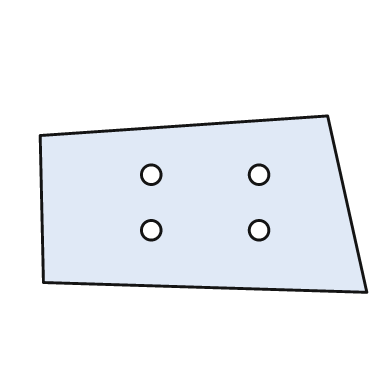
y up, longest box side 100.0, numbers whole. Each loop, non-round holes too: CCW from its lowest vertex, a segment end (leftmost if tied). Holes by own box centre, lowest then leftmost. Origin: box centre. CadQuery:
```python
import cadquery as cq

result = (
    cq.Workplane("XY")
    .moveTo(50.0, -27.0)
    .lineTo(38.0, 27.0)
    .lineTo(-50.0, 21.0)
    .lineTo(-49.0, -24.0)
    .close()
    .moveTo(-16.0, -8.0)
    .circle(3.0)
    .moveTo(17.0, -8.0)
    .circle(3.0)
    .moveTo(-16.0, 9.0)
    .circle(3.0)
    .moveTo(17.0, 9.0)
    .circle(3.0)
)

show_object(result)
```